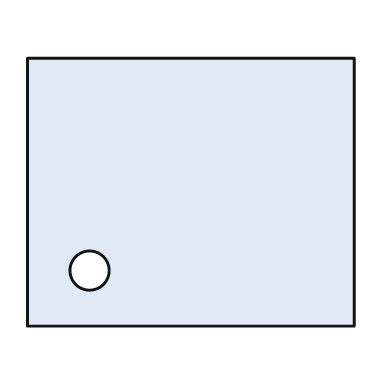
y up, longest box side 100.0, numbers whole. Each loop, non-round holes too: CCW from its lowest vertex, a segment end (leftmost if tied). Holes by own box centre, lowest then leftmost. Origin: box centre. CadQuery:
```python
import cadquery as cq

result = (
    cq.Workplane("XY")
    .moveTo(-50.0, -41.0)
    .lineTo(50.0, -41.0)
    .lineTo(50.0, 41.0)
    .lineTo(-50.0, 41.0)
    .close()
    .moveTo(-31.0, -24.0)
    .circle(6.0)
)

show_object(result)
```